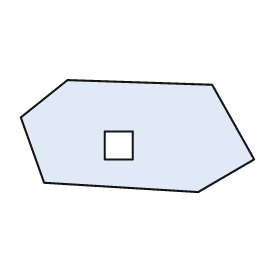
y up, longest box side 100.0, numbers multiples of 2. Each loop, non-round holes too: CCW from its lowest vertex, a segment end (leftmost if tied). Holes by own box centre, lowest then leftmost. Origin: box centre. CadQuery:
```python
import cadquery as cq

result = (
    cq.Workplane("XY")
    .moveTo(26.0, -24.0)
    .lineTo(50.0, -10.0)
    .lineTo(32.0, 22.0)
    .lineTo(-30.0, 24.0)
    .lineTo(-50.0, 8.0)
    .lineTo(-40.0, -20.0)
    .close()
    .moveTo(-14.0, -10.0)
    .lineTo(-2.0, -10.0)
    .lineTo(-2.0, 2.0)
    .lineTo(-14.0, 2.0)
    .close()
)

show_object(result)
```